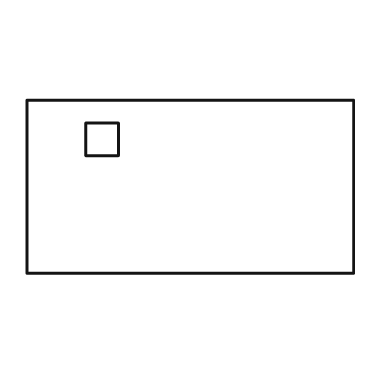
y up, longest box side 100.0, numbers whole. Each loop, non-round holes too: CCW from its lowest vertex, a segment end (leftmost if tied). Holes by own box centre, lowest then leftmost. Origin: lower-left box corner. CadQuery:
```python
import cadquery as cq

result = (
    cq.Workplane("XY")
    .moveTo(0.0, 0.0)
    .lineTo(100.0, 0.0)
    .lineTo(100.0, 53.0)
    .lineTo(0.0, 53.0)
    .close()
    .moveTo(18.0, 36.0)
    .lineTo(28.0, 36.0)
    .lineTo(28.0, 46.0)
    .lineTo(18.0, 46.0)
    .close()
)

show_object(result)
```